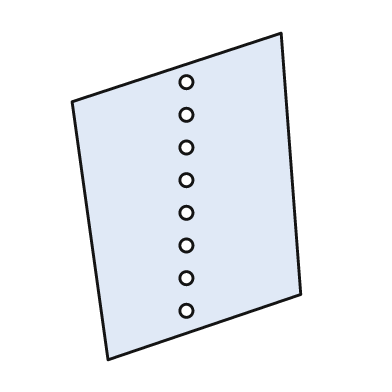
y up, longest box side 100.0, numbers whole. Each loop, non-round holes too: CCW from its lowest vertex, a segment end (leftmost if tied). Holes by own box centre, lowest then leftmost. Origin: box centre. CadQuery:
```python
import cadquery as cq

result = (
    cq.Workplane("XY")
    .moveTo(-24.0, -50.0)
    .lineTo(35.0, -30.0)
    .lineTo(29.0, 50.0)
    .lineTo(-35.0, 29.0)
    .close()
    .moveTo(0.0, -35.0)
    .circle(2.0)
    .moveTo(0.0, -25.0)
    .circle(2.0)
    .moveTo(0.0, -15.0)
    .circle(2.0)
    .moveTo(0.0, -5.0)
    .circle(2.0)
    .moveTo(0.0, 5.0)
    .circle(2.0)
    .moveTo(0.0, 15.0)
    .circle(2.0)
    .moveTo(0.0, 25.0)
    .circle(2.0)
    .moveTo(0.0, 35.0)
    .circle(2.0)
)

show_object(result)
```